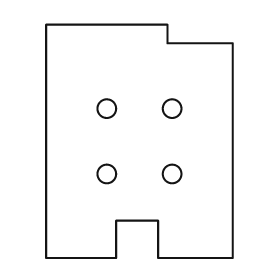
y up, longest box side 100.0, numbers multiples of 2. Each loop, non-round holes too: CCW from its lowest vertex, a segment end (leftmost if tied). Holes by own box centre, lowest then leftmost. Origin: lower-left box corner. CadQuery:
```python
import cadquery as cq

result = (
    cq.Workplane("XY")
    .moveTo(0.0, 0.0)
    .lineTo(30.0, 0.0)
    .lineTo(30.0, 16.0)
    .lineTo(48.0, 16.0)
    .lineTo(48.0, 0.0)
    .lineTo(80.0, 0.0)
    .lineTo(80.0, 92.0)
    .lineTo(52.0, 92.0)
    .lineTo(52.0, 100.0)
    .lineTo(0.0, 100.0)
    .close()
    .moveTo(26.0, 36.0)
    .circle(4.0)
    .moveTo(54.0, 36.0)
    .circle(4.0)
    .moveTo(26.0, 64.0)
    .circle(4.0)
    .moveTo(54.0, 64.0)
    .circle(4.0)
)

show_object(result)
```